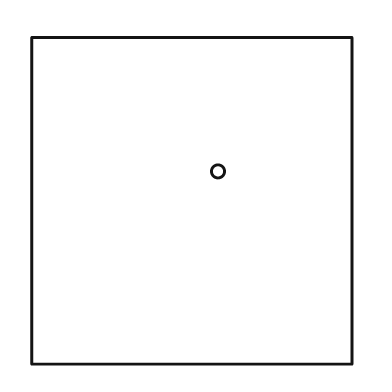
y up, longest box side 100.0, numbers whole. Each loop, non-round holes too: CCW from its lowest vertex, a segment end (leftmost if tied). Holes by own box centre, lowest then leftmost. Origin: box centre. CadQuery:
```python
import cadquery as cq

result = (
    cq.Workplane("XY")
    .moveTo(-49.0, -50.0)
    .lineTo(49.0, -50.0)
    .lineTo(49.0, 50.0)
    .lineTo(-49.0, 50.0)
    .close()
    .moveTo(8.0, 9.0)
    .circle(2.0)
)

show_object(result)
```